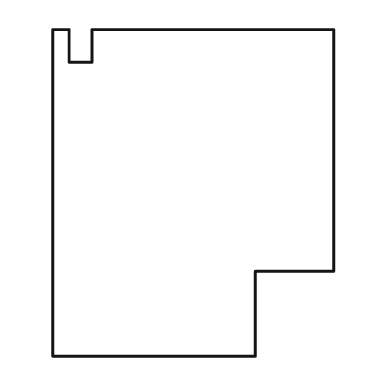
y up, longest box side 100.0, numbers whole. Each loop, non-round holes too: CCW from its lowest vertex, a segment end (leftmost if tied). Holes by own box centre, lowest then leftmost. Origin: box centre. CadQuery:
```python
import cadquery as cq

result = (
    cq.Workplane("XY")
    .moveTo(-43.0, -50.0)
    .lineTo(19.0, -50.0)
    .lineTo(19.0, -24.0)
    .lineTo(43.0, -24.0)
    .lineTo(43.0, 50.0)
    .lineTo(-31.0, 50.0)
    .lineTo(-31.0, 40.0)
    .lineTo(-38.0, 40.0)
    .lineTo(-38.0, 50.0)
    .lineTo(-43.0, 50.0)
    .close()
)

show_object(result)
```